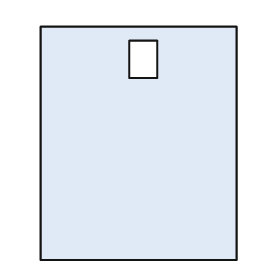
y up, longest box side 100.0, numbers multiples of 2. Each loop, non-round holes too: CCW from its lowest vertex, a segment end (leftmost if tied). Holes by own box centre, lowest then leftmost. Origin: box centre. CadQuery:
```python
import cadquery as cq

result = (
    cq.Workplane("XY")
    .moveTo(-42.0, -50.0)
    .lineTo(42.0, -50.0)
    .lineTo(42.0, 50.0)
    .lineTo(-42.0, 50.0)
    .close()
    .moveTo(-4.0, 28.0)
    .lineTo(8.0, 28.0)
    .lineTo(8.0, 44.0)
    .lineTo(-4.0, 44.0)
    .close()
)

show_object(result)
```